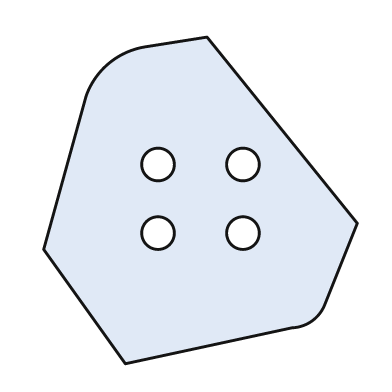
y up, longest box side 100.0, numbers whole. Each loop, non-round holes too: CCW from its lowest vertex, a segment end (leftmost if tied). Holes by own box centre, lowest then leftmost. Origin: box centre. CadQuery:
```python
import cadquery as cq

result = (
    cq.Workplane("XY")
    .moveTo(-23.0, -50.0)
    .lineTo(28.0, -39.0)
    .threePointArc((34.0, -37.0), (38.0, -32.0))
    .lineTo(48.0, -7.0)
    .lineTo(2.0, 50.0)
    .lineTo(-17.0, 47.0)
    .threePointArc((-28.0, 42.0), (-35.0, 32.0))
    .lineTo(-48.0, -15.0)
    .close()
    .moveTo(-13.0, -10.0)
    .circle(5.0)
    .moveTo(13.0, -10.0)
    .circle(5.0)
    .moveTo(-13.0, 11.0)
    .circle(5.0)
    .moveTo(13.0, 11.0)
    .circle(5.0)
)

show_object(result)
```